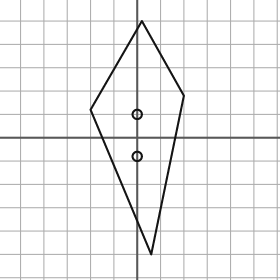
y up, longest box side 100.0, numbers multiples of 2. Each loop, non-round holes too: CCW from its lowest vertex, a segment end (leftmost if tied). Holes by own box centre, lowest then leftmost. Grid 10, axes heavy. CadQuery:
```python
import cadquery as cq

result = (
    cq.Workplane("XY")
    .moveTo(6.0, -50.0)
    .lineTo(20.0, 18.0)
    .lineTo(2.0, 50.0)
    .lineTo(-20.0, 12.0)
    .close()
    .moveTo(0.0, -8.0)
    .circle(2.0)
    .moveTo(0.0, 10.0)
    .circle(2.0)
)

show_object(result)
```